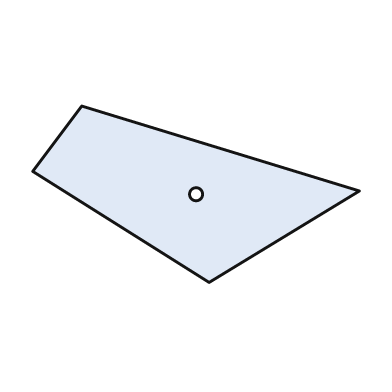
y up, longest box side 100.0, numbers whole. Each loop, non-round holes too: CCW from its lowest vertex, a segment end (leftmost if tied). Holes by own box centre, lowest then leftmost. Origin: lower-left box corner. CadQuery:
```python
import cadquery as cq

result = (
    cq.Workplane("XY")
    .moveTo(54.0, 0.0)
    .lineTo(100.0, 28.0)
    .lineTo(15.0, 54.0)
    .lineTo(0.0, 34.0)
    .close()
    .moveTo(50.0, 27.0)
    .circle(2.0)
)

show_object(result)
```